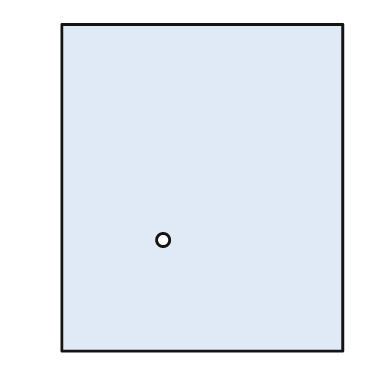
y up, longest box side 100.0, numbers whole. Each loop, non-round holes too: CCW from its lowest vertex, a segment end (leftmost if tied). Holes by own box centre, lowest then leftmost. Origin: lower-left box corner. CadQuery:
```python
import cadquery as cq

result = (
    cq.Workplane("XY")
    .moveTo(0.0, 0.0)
    .lineTo(86.0, 0.0)
    .lineTo(86.0, 100.0)
    .lineTo(0.0, 100.0)
    .close()
    .moveTo(31.0, 34.0)
    .circle(2.0)
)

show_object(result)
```